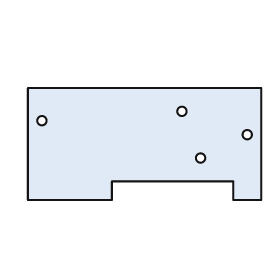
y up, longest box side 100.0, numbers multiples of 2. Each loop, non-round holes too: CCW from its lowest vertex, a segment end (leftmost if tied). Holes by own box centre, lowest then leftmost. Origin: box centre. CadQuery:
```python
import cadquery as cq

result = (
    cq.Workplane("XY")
    .moveTo(-50.0, -24.0)
    .lineTo(-14.0, -24.0)
    .lineTo(-14.0, -16.0)
    .lineTo(38.0, -16.0)
    .lineTo(38.0, -24.0)
    .lineTo(50.0, -24.0)
    .lineTo(50.0, 24.0)
    .lineTo(-50.0, 24.0)
    .close()
    .moveTo(24.0, -6.0)
    .circle(2.0)
    .moveTo(44.0, 4.0)
    .circle(2.0)
    .moveTo(-44.0, 10.0)
    .circle(2.0)
    .moveTo(16.0, 14.0)
    .circle(2.0)
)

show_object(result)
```